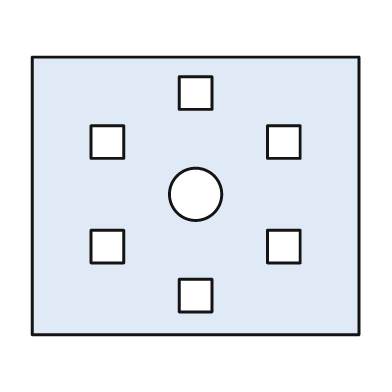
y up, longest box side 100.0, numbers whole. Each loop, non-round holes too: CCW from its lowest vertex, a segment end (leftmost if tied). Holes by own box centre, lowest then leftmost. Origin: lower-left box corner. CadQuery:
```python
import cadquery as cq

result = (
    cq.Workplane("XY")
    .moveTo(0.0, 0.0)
    .lineTo(100.0, 0.0)
    .lineTo(100.0, 85.0)
    .lineTo(0.0, 85.0)
    .close()
    .moveTo(45.0, 7.0)
    .lineTo(55.0, 7.0)
    .lineTo(55.0, 17.0)
    .lineTo(45.0, 17.0)
    .close()
    .moveTo(18.0, 22.0)
    .lineTo(28.0, 22.0)
    .lineTo(28.0, 32.0)
    .lineTo(18.0, 32.0)
    .close()
    .moveTo(72.0, 22.0)
    .lineTo(82.0, 22.0)
    .lineTo(82.0, 32.0)
    .lineTo(72.0, 32.0)
    .close()
    .moveTo(50.0, 43.0)
    .circle(8.0)
    .moveTo(18.0, 54.0)
    .lineTo(28.0, 54.0)
    .lineTo(28.0, 64.0)
    .lineTo(18.0, 64.0)
    .close()
    .moveTo(72.0, 54.0)
    .lineTo(82.0, 54.0)
    .lineTo(82.0, 64.0)
    .lineTo(72.0, 64.0)
    .close()
    .moveTo(45.0, 69.0)
    .lineTo(55.0, 69.0)
    .lineTo(55.0, 79.0)
    .lineTo(45.0, 79.0)
    .close()
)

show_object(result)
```